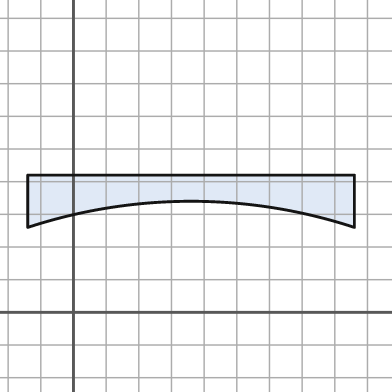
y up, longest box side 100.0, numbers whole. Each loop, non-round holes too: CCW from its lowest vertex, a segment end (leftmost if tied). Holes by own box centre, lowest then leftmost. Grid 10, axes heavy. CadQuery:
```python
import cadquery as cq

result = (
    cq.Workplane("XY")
    .moveTo(-14.0, 26.0)
    .threePointArc((36.0, 34.0), (86.0, 26.0))
    .lineTo(86.0, 42.0)
    .lineTo(-14.0, 42.0)
    .close()
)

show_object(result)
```